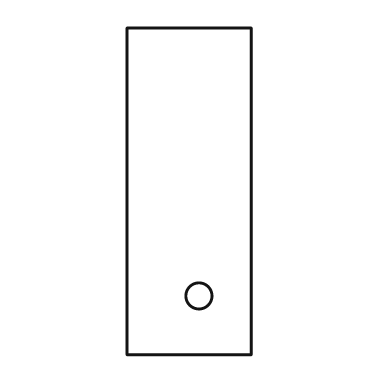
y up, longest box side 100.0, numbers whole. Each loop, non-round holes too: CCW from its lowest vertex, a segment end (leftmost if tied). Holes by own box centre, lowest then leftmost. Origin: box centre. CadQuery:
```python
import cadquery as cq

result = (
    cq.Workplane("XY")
    .moveTo(-19.0, -50.0)
    .lineTo(19.0, -50.0)
    .lineTo(19.0, 50.0)
    .lineTo(-19.0, 50.0)
    .close()
    .moveTo(3.0, -32.0)
    .circle(4.0)
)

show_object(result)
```